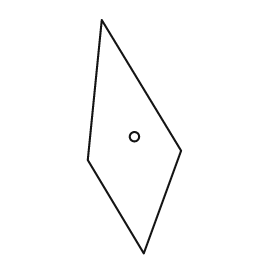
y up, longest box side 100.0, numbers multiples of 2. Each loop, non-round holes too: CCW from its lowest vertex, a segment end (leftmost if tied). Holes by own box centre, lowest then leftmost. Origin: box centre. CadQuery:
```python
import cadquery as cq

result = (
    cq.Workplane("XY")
    .moveTo(4.0, -50.0)
    .lineTo(20.0, -6.0)
    .lineTo(-14.0, 50.0)
    .lineTo(-20.0, -10.0)
    .close()
    .moveTo(0.0, 0.0)
    .circle(2.0)
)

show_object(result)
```